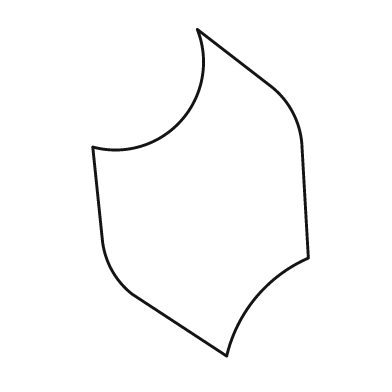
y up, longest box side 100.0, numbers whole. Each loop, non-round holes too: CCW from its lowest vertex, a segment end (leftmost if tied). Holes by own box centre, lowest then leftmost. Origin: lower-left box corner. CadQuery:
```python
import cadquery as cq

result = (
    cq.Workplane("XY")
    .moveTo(41.0, 0.0)
    .threePointArc((50.0, 18.0), (66.0, 30.0))
    .lineTo(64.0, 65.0)
    .threePointArc((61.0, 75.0), (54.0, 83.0))
    .lineTo(32.0, 100.0)
    .threePointArc((27.0, 72.0), (0.0, 64.0))
    .lineTo(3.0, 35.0)
    .threePointArc((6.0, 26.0), (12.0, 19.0))
    .close()
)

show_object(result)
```